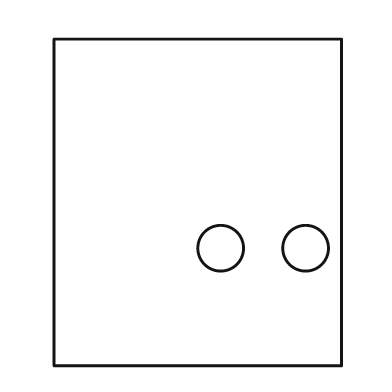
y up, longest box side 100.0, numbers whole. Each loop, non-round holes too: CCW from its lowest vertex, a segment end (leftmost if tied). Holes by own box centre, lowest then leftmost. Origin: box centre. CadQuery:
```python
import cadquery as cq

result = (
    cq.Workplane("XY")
    .moveTo(-44.0, -50.0)
    .lineTo(44.0, -50.0)
    .lineTo(44.0, 50.0)
    .lineTo(-44.0, 50.0)
    .close()
    .moveTo(7.0, -14.0)
    .circle(7.0)
    .moveTo(33.0, -14.0)
    .circle(7.0)
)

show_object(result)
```